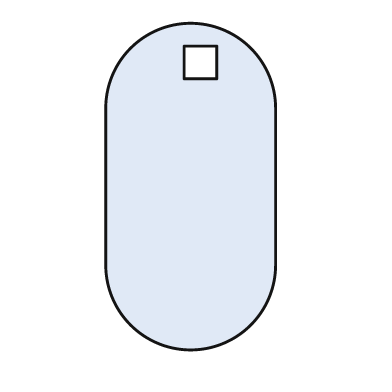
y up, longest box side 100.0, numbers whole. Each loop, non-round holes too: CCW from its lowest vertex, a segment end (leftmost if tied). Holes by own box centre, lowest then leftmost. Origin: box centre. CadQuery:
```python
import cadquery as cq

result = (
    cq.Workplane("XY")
    .moveTo(-26.0, -24.0)
    .threePointArc((0.0, -50.0), (26.0, -24.0))
    .lineTo(26.0, 24.0)
    .threePointArc((0.0, 50.0), (-26.0, 24.0))
    .close()
    .moveTo(-2.0, 33.0)
    .lineTo(8.0, 33.0)
    .lineTo(8.0, 43.0)
    .lineTo(-2.0, 43.0)
    .close()
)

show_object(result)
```